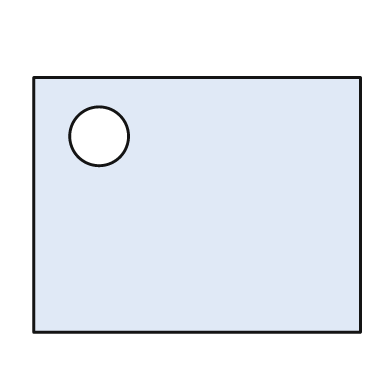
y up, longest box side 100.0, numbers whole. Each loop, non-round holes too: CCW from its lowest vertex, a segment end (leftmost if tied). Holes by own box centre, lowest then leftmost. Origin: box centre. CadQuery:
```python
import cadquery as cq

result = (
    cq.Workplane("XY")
    .moveTo(-50.0, -39.0)
    .lineTo(50.0, -39.0)
    .lineTo(50.0, 39.0)
    .lineTo(-50.0, 39.0)
    .close()
    .moveTo(-30.0, 21.0)
    .circle(9.0)
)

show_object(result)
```